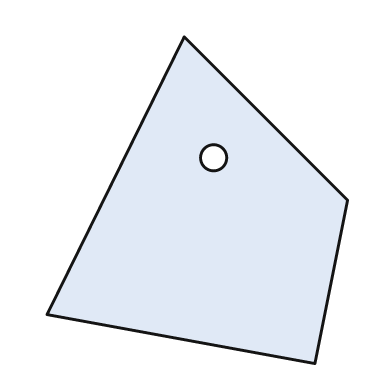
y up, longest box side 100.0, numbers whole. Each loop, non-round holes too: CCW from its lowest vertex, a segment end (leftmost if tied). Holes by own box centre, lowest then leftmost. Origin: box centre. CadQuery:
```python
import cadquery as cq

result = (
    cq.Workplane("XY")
    .moveTo(36.0, -50.0)
    .lineTo(46.0, 0.0)
    .lineTo(-4.0, 50.0)
    .lineTo(-46.0, -35.0)
    .close()
    .moveTo(5.0, 13.0)
    .circle(4.0)
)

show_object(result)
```